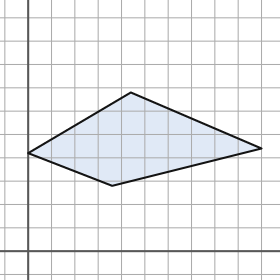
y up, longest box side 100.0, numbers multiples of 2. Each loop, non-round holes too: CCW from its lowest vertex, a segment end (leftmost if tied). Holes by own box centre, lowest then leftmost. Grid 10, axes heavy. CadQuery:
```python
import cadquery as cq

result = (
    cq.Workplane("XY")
    .moveTo(36.0, 28.0)
    .lineTo(100.0, 44.0)
    .lineTo(44.0, 68.0)
    .lineTo(0.0, 42.0)
    .close()
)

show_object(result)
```